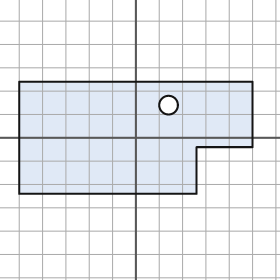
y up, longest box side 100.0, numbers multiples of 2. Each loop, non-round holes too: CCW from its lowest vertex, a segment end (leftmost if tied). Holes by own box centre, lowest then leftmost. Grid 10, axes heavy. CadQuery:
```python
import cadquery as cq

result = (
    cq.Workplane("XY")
    .moveTo(-50.0, -24.0)
    .lineTo(26.0, -24.0)
    .lineTo(26.0, -4.0)
    .lineTo(50.0, -4.0)
    .lineTo(50.0, 24.0)
    .lineTo(-50.0, 24.0)
    .close()
    .moveTo(14.0, 14.0)
    .circle(4.0)
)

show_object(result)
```